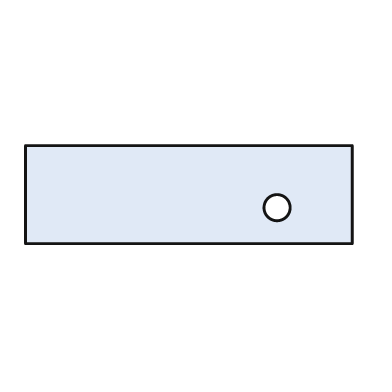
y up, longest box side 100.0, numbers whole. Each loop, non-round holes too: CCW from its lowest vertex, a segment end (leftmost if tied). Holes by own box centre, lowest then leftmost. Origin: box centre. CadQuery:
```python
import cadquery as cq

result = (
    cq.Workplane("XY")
    .moveTo(-50.0, -15.0)
    .lineTo(50.0, -15.0)
    .lineTo(50.0, 15.0)
    .lineTo(-50.0, 15.0)
    .close()
    .moveTo(27.0, -4.0)
    .circle(4.0)
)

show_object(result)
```